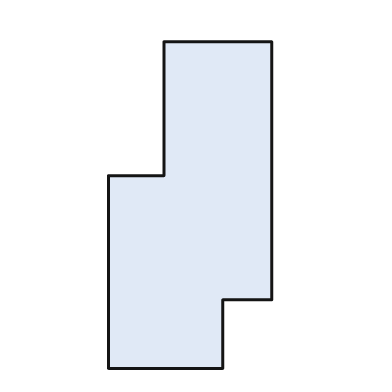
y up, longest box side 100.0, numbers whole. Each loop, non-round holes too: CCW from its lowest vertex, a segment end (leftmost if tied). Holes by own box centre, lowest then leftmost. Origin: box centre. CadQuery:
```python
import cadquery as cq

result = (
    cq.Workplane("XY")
    .moveTo(-25.0, -50.0)
    .lineTo(10.0, -50.0)
    .lineTo(10.0, -29.0)
    .lineTo(25.0, -29.0)
    .lineTo(25.0, 50.0)
    .lineTo(-8.0, 50.0)
    .lineTo(-8.0, 9.0)
    .lineTo(-25.0, 9.0)
    .close()
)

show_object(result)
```